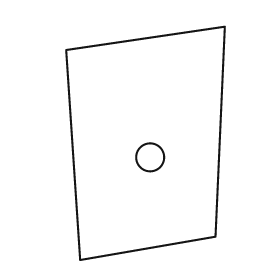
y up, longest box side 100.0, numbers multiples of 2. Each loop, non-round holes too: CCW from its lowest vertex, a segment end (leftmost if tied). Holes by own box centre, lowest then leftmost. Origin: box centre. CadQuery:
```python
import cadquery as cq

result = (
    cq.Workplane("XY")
    .moveTo(-28.0, -50.0)
    .lineTo(30.0, -40.0)
    .lineTo(34.0, 50.0)
    .lineTo(-34.0, 40.0)
    .close()
    .moveTo(2.0, -6.0)
    .circle(6.0)
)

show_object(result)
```